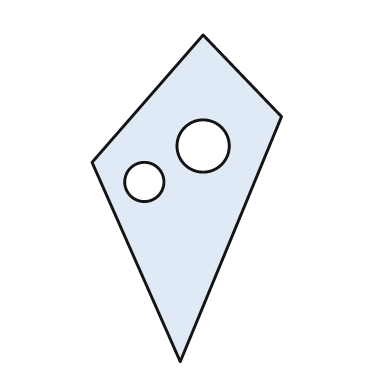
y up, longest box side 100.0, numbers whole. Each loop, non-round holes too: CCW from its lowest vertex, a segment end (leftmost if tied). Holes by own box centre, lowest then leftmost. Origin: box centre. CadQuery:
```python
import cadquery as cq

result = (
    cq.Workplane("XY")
    .moveTo(-2.0, -50.0)
    .lineTo(29.0, 25.0)
    .lineTo(5.0, 50.0)
    .lineTo(-29.0, 11.0)
    .close()
    .moveTo(-13.0, 5.0)
    .circle(6.0)
    .moveTo(5.0, 16.0)
    .circle(8.0)
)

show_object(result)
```